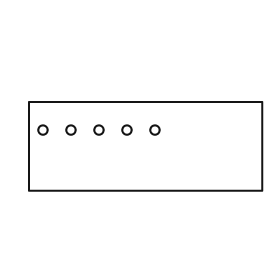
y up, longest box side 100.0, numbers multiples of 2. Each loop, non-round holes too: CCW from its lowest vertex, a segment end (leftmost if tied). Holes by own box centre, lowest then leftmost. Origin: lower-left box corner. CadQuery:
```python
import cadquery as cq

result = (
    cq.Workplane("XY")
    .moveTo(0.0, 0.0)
    .lineTo(100.0, 0.0)
    .lineTo(100.0, 38.0)
    .lineTo(0.0, 38.0)
    .close()
    .moveTo(6.0, 26.0)
    .circle(2.0)
    .moveTo(18.0, 26.0)
    .circle(2.0)
    .moveTo(30.0, 26.0)
    .circle(2.0)
    .moveTo(42.0, 26.0)
    .circle(2.0)
    .moveTo(54.0, 26.0)
    .circle(2.0)
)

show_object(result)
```